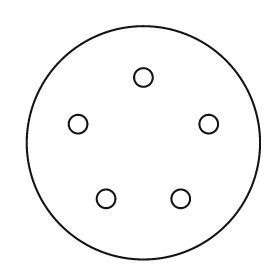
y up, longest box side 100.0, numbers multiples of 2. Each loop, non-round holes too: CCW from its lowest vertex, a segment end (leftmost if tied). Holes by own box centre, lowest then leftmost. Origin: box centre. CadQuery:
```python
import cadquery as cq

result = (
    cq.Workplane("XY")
    .moveTo(0.0, 0.0)
    .circle(50.0)
    .moveTo(-16.0, -24.0)
    .circle(4.0)
    .moveTo(16.0, -24.0)
    .circle(4.0)
    .moveTo(-28.0, 8.0)
    .circle(4.0)
    .moveTo(28.0, 8.0)
    .circle(4.0)
    .moveTo(0.0, 28.0)
    .circle(4.0)
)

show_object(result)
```